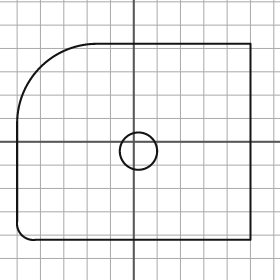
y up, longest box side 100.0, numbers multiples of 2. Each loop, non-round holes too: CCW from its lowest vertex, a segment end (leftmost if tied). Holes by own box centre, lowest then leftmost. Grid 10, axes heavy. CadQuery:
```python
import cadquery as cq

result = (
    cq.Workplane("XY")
    .moveTo(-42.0, -42.0)
    .lineTo(50.0, -42.0)
    .lineTo(50.0, 42.0)
    .lineTo(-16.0, 42.0)
    .threePointArc((-40.0, 32.0), (-50.0, 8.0))
    .lineTo(-50.0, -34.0)
    .threePointArc((-48.0, -40.0), (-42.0, -42.0))
    .close()
    .moveTo(2.0, -4.0)
    .circle(8.0)
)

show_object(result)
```